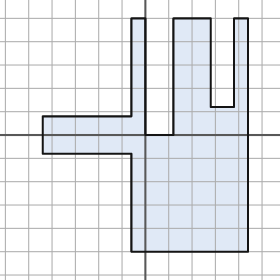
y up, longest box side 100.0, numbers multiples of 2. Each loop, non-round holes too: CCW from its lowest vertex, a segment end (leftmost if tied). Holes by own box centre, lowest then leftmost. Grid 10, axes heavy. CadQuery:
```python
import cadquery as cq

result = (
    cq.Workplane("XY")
    .moveTo(-6.0, -50.0)
    .lineTo(44.0, -50.0)
    .lineTo(44.0, 50.0)
    .lineTo(38.0, 50.0)
    .lineTo(38.0, 12.0)
    .lineTo(28.0, 12.0)
    .lineTo(28.0, 50.0)
    .lineTo(12.0, 50.0)
    .lineTo(12.0, 0.0)
    .lineTo(0.0, 0.0)
    .lineTo(0.0, 50.0)
    .lineTo(-6.0, 50.0)
    .lineTo(-6.0, 8.0)
    .lineTo(-44.0, 8.0)
    .lineTo(-44.0, -8.0)
    .lineTo(-6.0, -8.0)
    .close()
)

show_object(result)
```